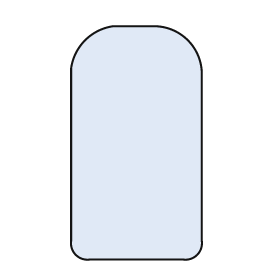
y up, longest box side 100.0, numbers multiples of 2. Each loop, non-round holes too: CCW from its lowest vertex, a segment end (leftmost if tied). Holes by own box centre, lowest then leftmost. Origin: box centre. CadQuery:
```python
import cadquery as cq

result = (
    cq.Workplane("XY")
    .moveTo(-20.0, -50.0)
    .lineTo(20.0, -50.0)
    .threePointArc((26.0, -48.0), (28.0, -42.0))
    .lineTo(28.0, 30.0)
    .threePointArc((22.0, 44.0), (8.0, 50.0))
    .lineTo(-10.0, 50.0)
    .threePointArc((-22.0, 44.0), (-28.0, 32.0))
    .lineTo(-28.0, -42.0)
    .threePointArc((-26.0, -48.0), (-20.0, -50.0))
    .close()
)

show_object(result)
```